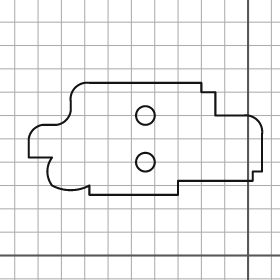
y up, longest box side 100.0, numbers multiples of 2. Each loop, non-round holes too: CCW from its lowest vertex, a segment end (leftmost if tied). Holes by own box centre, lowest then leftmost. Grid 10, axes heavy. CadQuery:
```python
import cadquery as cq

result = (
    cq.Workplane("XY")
    .moveTo(-68.0, 26.0)
    .lineTo(-30.0, 26.0)
    .lineTo(-30.0, 32.0)
    .lineTo(2.0, 32.0)
    .lineTo(2.0, 36.0)
    .lineTo(6.0, 36.0)
    .lineTo(6.0, 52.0)
    .threePointArc((4.0, 58.0), (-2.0, 60.0))
    .lineTo(-14.0, 60.0)
    .lineTo(-14.0, 70.0)
    .lineTo(-20.0, 70.0)
    .lineTo(-20.0, 74.0)
    .lineTo(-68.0, 74.0)
    .threePointArc((-74.0, 72.0), (-76.0, 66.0))
    .lineTo(-76.0, 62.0)
    .threePointArc((-78.0, 58.0), (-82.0, 56.0))
    .lineTo(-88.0, 56.0)
    .threePointArc((-92.0, 54.0), (-94.0, 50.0))
    .lineTo(-94.0, 42.0)
    .lineTo(-84.0, 42.0)
    .threePointArc((-86.0, 36.0), (-84.0, 30.0))
    .threePointArc((-76.0, 28.0), (-68.0, 30.0))
    .close()
    .moveTo(-44.0, 40.0)
    .circle(4.0)
    .moveTo(-44.0, 60.0)
    .circle(4.0)
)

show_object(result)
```